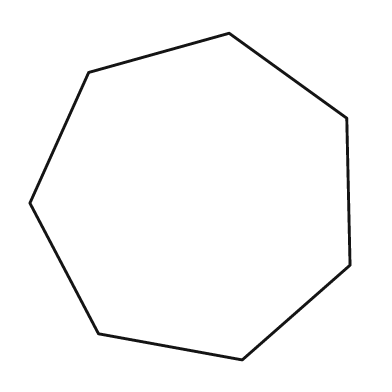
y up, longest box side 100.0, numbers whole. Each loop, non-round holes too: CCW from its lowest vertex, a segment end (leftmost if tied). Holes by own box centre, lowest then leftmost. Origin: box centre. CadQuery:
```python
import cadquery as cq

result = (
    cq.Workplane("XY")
    .moveTo(16.0, -50.0)
    .lineTo(49.0, -21.0)
    .lineTo(48.0, 24.0)
    .lineTo(12.0, 50.0)
    .lineTo(-31.0, 38.0)
    .lineTo(-49.0, -2.0)
    .lineTo(-28.0, -42.0)
    .close()
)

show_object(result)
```